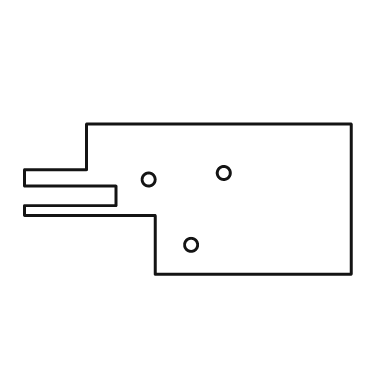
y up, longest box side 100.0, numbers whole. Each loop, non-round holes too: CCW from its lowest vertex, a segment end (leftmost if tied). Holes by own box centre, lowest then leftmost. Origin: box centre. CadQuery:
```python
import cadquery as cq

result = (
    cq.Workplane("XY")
    .moveTo(-10.0, -23.0)
    .lineTo(50.0, -23.0)
    .lineTo(50.0, 23.0)
    .lineTo(-31.0, 23.0)
    .lineTo(-31.0, 9.0)
    .lineTo(-50.0, 9.0)
    .lineTo(-50.0, 4.0)
    .lineTo(-22.0, 4.0)
    .lineTo(-22.0, -2.0)
    .lineTo(-50.0, -2.0)
    .lineTo(-50.0, -5.0)
    .lineTo(-10.0, -5.0)
    .close()
    .moveTo(1.0, -14.0)
    .circle(2.0)
    .moveTo(-12.0, 6.0)
    .circle(2.0)
    .moveTo(11.0, 8.0)
    .circle(2.0)
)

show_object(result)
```